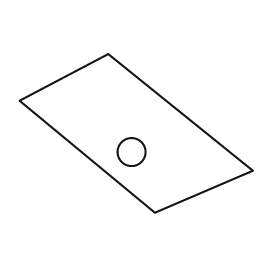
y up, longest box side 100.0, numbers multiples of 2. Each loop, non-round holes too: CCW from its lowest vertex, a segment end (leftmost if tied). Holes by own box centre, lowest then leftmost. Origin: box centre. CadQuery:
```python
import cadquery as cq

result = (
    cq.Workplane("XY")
    .moveTo(8.0, -34.0)
    .lineTo(50.0, -16.0)
    .lineTo(-12.0, 34.0)
    .lineTo(-50.0, 14.0)
    .close()
    .moveTo(-2.0, -8.0)
    .circle(6.0)
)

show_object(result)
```